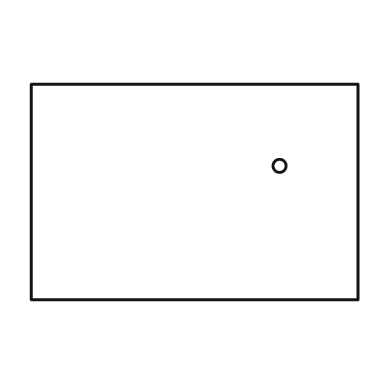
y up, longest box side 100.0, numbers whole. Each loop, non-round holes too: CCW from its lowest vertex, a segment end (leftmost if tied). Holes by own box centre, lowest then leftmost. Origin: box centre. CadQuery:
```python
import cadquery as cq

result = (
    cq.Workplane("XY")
    .moveTo(-50.0, -33.0)
    .lineTo(50.0, -33.0)
    .lineTo(50.0, 33.0)
    .lineTo(-50.0, 33.0)
    .close()
    .moveTo(26.0, 8.0)
    .circle(2.0)
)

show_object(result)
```